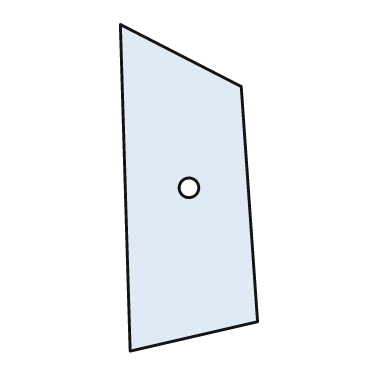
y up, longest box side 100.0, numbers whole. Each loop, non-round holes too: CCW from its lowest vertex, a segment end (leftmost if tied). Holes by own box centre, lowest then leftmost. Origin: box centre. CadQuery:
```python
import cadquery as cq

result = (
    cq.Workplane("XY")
    .moveTo(-18.0, -50.0)
    .lineTo(21.0, -41.0)
    .lineTo(16.0, 31.0)
    .lineTo(-21.0, 50.0)
    .close()
    .moveTo(0.0, 0.0)
    .circle(3.0)
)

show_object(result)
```